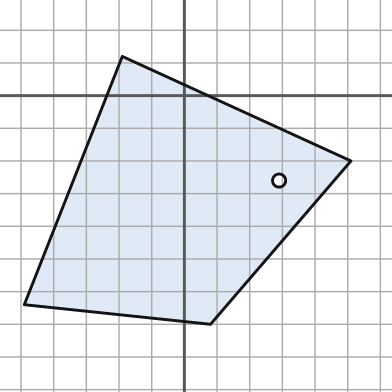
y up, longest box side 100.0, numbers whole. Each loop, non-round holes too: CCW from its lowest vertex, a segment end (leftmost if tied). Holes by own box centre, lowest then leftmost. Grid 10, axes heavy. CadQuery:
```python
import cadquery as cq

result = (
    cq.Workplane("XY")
    .moveTo(8.0, -70.0)
    .lineTo(51.0, -20.0)
    .lineTo(-19.0, 12.0)
    .lineTo(-49.0, -64.0)
    .close()
    .moveTo(29.0, -26.0)
    .circle(2.0)
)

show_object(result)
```